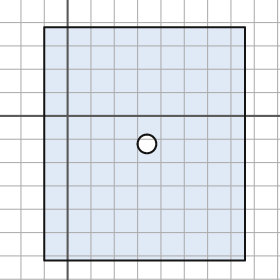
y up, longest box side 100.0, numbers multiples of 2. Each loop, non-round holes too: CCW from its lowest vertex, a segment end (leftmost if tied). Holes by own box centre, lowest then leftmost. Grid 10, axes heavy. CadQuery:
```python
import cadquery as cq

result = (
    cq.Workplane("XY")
    .moveTo(-10.0, -62.0)
    .lineTo(76.0, -62.0)
    .lineTo(76.0, 38.0)
    .lineTo(-10.0, 38.0)
    .close()
    .moveTo(34.0, -12.0)
    .circle(4.0)
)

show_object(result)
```